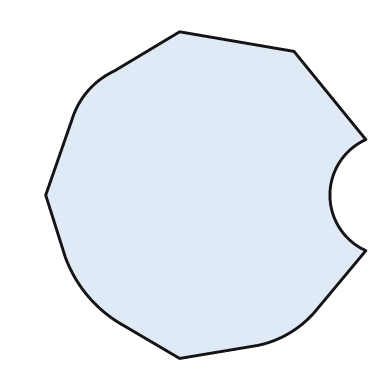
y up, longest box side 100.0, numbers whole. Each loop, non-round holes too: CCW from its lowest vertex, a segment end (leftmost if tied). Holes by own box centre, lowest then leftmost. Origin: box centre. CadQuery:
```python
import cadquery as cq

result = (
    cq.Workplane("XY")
    .moveTo(-8.0, -50.0)
    .lineTo(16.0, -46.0)
    .threePointArc((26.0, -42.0), (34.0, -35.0))
    .lineTo(49.0, -17.0)
    .threePointArc((38.0, 0.0), (49.0, 17.0))
    .lineTo(27.0, 44.0)
    .lineTo(-8.0, 50.0)
    .lineTo(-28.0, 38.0)
    .threePointArc((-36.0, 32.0), (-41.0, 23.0))
    .lineTo(-49.0, 0.0)
    .lineTo(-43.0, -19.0)
    .threePointArc((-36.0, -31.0), (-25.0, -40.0))
    .close()
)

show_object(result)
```